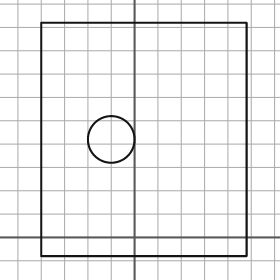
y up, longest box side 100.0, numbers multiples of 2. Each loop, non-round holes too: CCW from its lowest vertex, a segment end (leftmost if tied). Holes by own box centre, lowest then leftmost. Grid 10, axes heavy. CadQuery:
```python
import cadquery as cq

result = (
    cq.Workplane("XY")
    .moveTo(-40.0, -8.0)
    .lineTo(48.0, -8.0)
    .lineTo(48.0, 92.0)
    .lineTo(-40.0, 92.0)
    .close()
    .moveTo(-10.0, 42.0)
    .circle(10.0)
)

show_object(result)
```